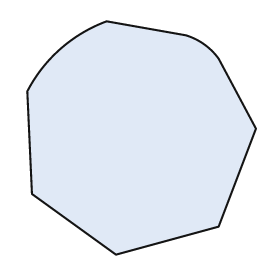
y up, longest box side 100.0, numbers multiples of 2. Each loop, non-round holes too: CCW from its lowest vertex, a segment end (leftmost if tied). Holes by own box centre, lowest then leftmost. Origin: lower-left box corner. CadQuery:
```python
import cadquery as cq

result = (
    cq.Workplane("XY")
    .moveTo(38.0, 0.0)
    .lineTo(82.0, 12.0)
    .lineTo(98.0, 54.0)
    .lineTo(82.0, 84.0)
    .threePointArc((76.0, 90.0), (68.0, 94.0))
    .lineTo(34.0, 100.0)
    .threePointArc((14.0, 88.0), (0.0, 70.0))
    .lineTo(2.0, 26.0)
    .close()
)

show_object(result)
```